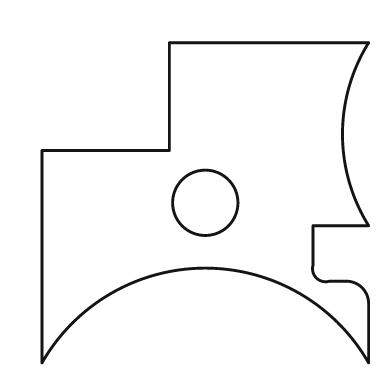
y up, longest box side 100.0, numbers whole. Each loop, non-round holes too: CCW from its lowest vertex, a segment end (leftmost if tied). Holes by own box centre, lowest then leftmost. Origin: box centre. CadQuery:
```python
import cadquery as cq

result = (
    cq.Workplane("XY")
    .moveTo(-50.0, -49.0)
    .threePointArc((0.0, -20.0), (50.0, -49.0))
    .lineTo(50.0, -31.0)
    .threePointArc((48.0, -26.0), (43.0, -24.0))
    .lineTo(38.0, -24.0)
    .threePointArc((34.0, -23.0), (33.0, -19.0))
    .lineTo(33.0, -7.0)
    .lineTo(50.0, -7.0)
    .threePointArc((42.0, 21.0), (50.0, 49.0))
    .lineTo(-11.0, 49.0)
    .lineTo(-11.0, 16.0)
    .lineTo(-50.0, 16.0)
    .close()
    .moveTo(0.0, 0.0)
    .circle(10.0)
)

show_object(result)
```